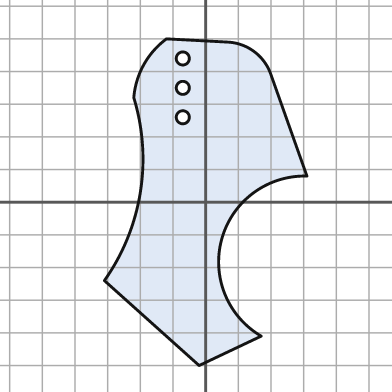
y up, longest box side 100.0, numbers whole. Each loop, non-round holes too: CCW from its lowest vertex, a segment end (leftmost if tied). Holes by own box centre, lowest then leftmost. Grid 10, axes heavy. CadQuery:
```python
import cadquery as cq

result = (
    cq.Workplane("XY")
    .moveTo(-2.0, -50.0)
    .lineTo(17.0, -41.0)
    .threePointArc((5.0, -11.0), (31.0, 8.0))
    .lineTo(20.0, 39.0)
    .threePointArc((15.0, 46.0), (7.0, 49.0))
    .lineTo(-12.0, 50.0)
    .threePointArc((-19.0, 42.0), (-22.0, 32.0))
    .threePointArc((-20.0, 3.0), (-31.0, -24.0))
    .close()
    .moveTo(-7.0, 26.0)
    .circle(2.0)
    .moveTo(-7.0, 35.0)
    .circle(2.0)
    .moveTo(-7.0, 44.0)
    .circle(2.0)
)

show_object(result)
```